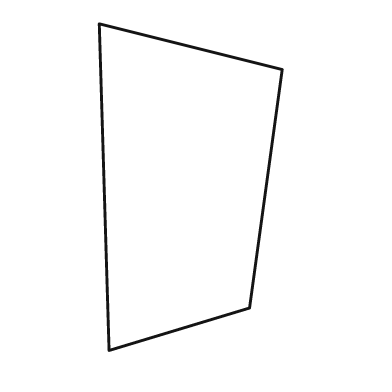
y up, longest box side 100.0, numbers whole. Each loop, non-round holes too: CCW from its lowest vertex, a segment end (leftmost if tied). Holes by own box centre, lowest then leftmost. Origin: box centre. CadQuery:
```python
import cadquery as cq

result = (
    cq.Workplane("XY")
    .moveTo(-25.0, -50.0)
    .lineTo(18.0, -37.0)
    .lineTo(28.0, 36.0)
    .lineTo(-28.0, 50.0)
    .close()
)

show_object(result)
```